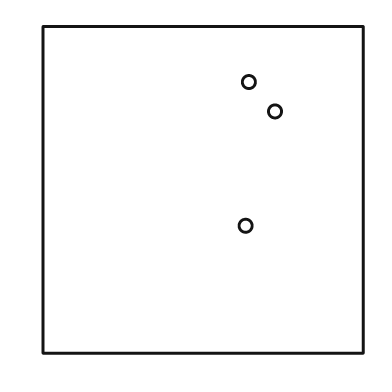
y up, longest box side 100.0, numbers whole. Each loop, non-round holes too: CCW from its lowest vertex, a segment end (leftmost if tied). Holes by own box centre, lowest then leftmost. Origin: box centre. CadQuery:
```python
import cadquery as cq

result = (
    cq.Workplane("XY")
    .moveTo(-49.0, -50.0)
    .lineTo(49.0, -50.0)
    .lineTo(49.0, 50.0)
    .lineTo(-49.0, 50.0)
    .close()
    .moveTo(13.0, -11.0)
    .circle(2.0)
    .moveTo(22.0, 24.0)
    .circle(2.0)
    .moveTo(14.0, 33.0)
    .circle(2.0)
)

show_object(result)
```